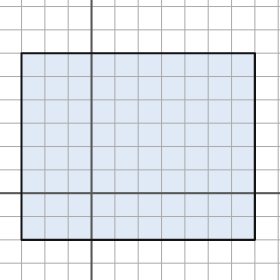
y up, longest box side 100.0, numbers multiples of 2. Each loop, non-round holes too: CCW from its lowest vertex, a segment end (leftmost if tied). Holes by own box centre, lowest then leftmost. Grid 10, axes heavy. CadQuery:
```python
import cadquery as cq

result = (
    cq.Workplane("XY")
    .moveTo(-30.0, -20.0)
    .lineTo(70.0, -20.0)
    .lineTo(70.0, 60.0)
    .lineTo(-30.0, 60.0)
    .close()
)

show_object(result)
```